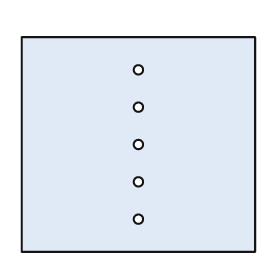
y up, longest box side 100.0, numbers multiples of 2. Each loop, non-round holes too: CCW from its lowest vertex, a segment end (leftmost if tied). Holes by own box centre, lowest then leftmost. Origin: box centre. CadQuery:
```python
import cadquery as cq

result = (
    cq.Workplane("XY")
    .moveTo(-50.0, -46.0)
    .lineTo(50.0, -46.0)
    .lineTo(50.0, 46.0)
    .lineTo(-50.0, 46.0)
    .close()
    .moveTo(0.0, -32.0)
    .circle(2.0)
    .moveTo(0.0, -16.0)
    .circle(2.0)
    .moveTo(0.0, 0.0)
    .circle(2.0)
    .moveTo(0.0, 16.0)
    .circle(2.0)
    .moveTo(0.0, 32.0)
    .circle(2.0)
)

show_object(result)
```